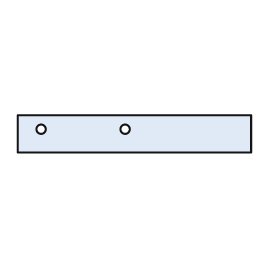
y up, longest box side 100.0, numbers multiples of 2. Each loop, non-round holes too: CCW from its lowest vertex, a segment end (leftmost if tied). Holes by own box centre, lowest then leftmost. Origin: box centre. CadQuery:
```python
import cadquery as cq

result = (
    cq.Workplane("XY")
    .moveTo(-50.0, -8.0)
    .lineTo(50.0, -8.0)
    .lineTo(50.0, 8.0)
    .lineTo(-50.0, 8.0)
    .close()
    .moveTo(-40.0, 2.0)
    .circle(2.0)
    .moveTo(-4.0, 2.0)
    .circle(2.0)
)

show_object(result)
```